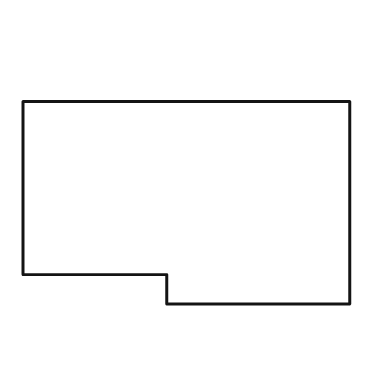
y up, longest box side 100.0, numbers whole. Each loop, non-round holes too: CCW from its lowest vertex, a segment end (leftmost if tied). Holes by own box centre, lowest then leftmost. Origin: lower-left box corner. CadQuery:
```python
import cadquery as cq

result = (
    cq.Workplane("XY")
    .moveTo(44.0, 0.0)
    .lineTo(100.0, 0.0)
    .lineTo(100.0, 62.0)
    .lineTo(0.0, 62.0)
    .lineTo(0.0, 9.0)
    .lineTo(44.0, 9.0)
    .close()
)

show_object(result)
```